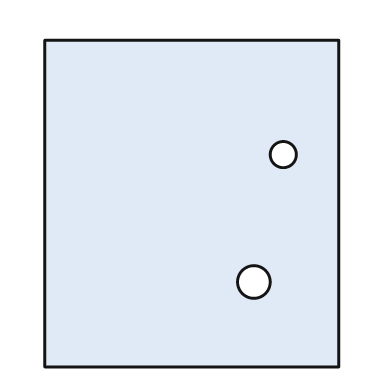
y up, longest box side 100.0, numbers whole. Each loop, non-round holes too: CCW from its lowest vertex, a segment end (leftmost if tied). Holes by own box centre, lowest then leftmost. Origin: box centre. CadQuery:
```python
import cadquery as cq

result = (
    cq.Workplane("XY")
    .moveTo(-45.0, -50.0)
    .lineTo(45.0, -50.0)
    .lineTo(45.0, 50.0)
    .lineTo(-45.0, 50.0)
    .close()
    .moveTo(19.0, -24.0)
    .circle(5.0)
    .moveTo(28.0, 15.0)
    .circle(4.0)
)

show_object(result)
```